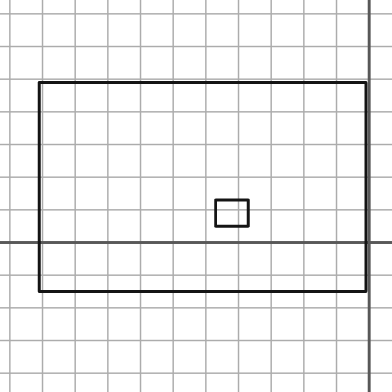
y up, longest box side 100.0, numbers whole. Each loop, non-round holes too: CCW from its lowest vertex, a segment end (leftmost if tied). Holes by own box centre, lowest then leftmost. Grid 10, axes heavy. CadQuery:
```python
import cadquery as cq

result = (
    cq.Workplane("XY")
    .moveTo(-101.0, -15.0)
    .lineTo(-1.0, -15.0)
    .lineTo(-1.0, 49.0)
    .lineTo(-101.0, 49.0)
    .close()
    .moveTo(-47.0, 5.0)
    .lineTo(-37.0, 5.0)
    .lineTo(-37.0, 13.0)
    .lineTo(-47.0, 13.0)
    .close()
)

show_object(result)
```